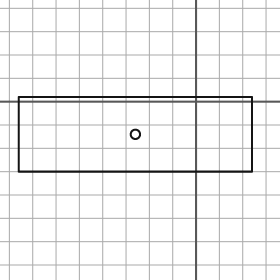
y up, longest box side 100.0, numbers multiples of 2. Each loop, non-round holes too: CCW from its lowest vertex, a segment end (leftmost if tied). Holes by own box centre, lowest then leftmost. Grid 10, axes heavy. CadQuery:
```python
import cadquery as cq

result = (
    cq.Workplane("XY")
    .moveTo(-76.0, -30.0)
    .lineTo(24.0, -30.0)
    .lineTo(24.0, 2.0)
    .lineTo(-76.0, 2.0)
    .close()
    .moveTo(-26.0, -14.0)
    .circle(2.0)
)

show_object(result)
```